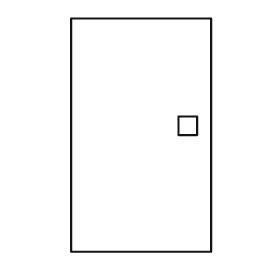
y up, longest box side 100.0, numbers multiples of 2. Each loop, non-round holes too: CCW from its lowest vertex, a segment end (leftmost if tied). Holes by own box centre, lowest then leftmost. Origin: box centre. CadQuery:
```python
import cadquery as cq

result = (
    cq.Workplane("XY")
    .moveTo(-30.0, -50.0)
    .lineTo(30.0, -50.0)
    .lineTo(30.0, 50.0)
    .lineTo(-30.0, 50.0)
    .close()
    .moveTo(16.0, 0.0)
    .lineTo(24.0, 0.0)
    .lineTo(24.0, 8.0)
    .lineTo(16.0, 8.0)
    .close()
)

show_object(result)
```